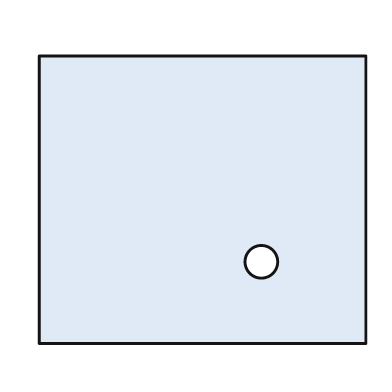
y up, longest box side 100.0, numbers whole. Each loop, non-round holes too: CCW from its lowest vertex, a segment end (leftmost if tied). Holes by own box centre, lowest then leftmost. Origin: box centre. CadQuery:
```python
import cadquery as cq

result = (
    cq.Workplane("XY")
    .moveTo(-50.0, -44.0)
    .lineTo(50.0, -44.0)
    .lineTo(50.0, 44.0)
    .lineTo(-50.0, 44.0)
    .close()
    .moveTo(18.0, -19.0)
    .circle(5.0)
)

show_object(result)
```